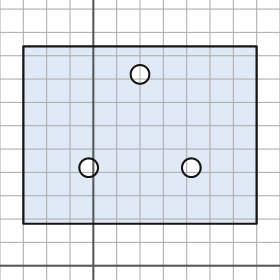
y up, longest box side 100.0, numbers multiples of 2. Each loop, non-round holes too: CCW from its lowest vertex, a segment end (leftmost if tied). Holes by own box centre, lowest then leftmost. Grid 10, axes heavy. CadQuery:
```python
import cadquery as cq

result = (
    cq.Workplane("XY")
    .moveTo(-30.0, 18.0)
    .lineTo(70.0, 18.0)
    .lineTo(70.0, 94.0)
    .lineTo(-30.0, 94.0)
    .close()
    .moveTo(-2.0, 42.0)
    .circle(4.0)
    .moveTo(42.0, 42.0)
    .circle(4.0)
    .moveTo(20.0, 82.0)
    .circle(4.0)
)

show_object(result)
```